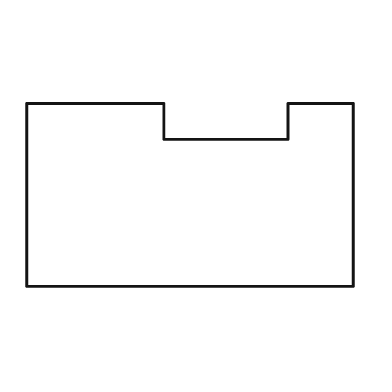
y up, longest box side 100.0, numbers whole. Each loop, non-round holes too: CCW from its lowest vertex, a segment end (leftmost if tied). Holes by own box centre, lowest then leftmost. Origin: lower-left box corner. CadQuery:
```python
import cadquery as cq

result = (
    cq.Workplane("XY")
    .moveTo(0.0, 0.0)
    .lineTo(100.0, 0.0)
    .lineTo(100.0, 56.0)
    .lineTo(80.0, 56.0)
    .lineTo(80.0, 45.0)
    .lineTo(42.0, 45.0)
    .lineTo(42.0, 56.0)
    .lineTo(0.0, 56.0)
    .close()
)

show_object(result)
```